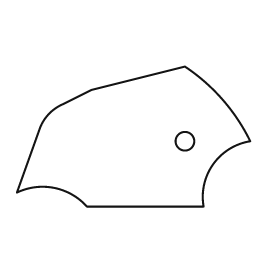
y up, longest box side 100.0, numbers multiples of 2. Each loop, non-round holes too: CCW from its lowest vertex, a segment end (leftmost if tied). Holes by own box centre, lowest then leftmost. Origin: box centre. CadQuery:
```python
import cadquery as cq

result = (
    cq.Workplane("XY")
    .moveTo(-20.0, -30.0)
    .lineTo(30.0, -30.0)
    .threePointArc((34.0, -12.0), (50.0, -2.0))
    .threePointArc((38.0, 16.0), (22.0, 30.0))
    .lineTo(-18.0, 20.0)
    .lineTo(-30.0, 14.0)
    .threePointArc((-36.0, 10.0), (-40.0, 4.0))
    .lineTo(-50.0, -24.0)
    .threePointArc((-34.0, -22.0), (-20.0, -30.0))
    .close()
    .moveTo(22.0, -2.0)
    .circle(4.0)
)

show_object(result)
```